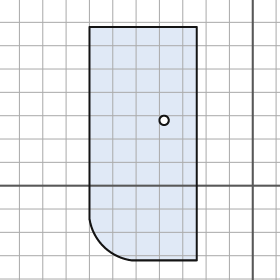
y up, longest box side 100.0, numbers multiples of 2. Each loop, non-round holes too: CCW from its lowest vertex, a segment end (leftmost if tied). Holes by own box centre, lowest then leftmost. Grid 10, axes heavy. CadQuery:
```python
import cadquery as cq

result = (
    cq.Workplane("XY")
    .moveTo(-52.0, -32.0)
    .lineTo(-24.0, -32.0)
    .lineTo(-24.0, 68.0)
    .lineTo(-70.0, 68.0)
    .lineTo(-70.0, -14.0)
    .threePointArc((-64.0, -26.0), (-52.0, -32.0))
    .close()
    .moveTo(-38.0, 28.0)
    .circle(2.0)
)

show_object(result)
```